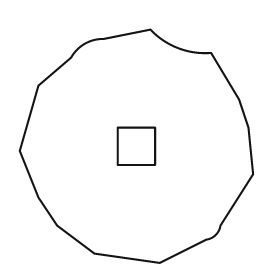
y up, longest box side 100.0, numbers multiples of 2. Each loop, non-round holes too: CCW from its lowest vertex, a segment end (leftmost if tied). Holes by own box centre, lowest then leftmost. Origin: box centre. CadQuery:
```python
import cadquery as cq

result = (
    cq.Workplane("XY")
    .moveTo(10.0, -50.0)
    .lineTo(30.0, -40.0)
    .threePointArc((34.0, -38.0), (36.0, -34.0))
    .lineTo(50.0, -12.0)
    .lineTo(48.0, 8.0)
    .lineTo(44.0, 20.0)
    .lineTo(32.0, 40.0)
    .threePointArc((18.0, 42.0), (6.0, 50.0))
    .lineTo(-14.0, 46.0)
    .threePointArc((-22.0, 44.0), (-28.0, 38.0))
    .lineTo(-42.0, 26.0)
    .lineTo(-50.0, -2.0)
    .lineTo(-42.0, -22.0)
    .lineTo(-34.0, -34.0)
    .lineTo(-18.0, -46.0)
    .close()
    .moveTo(-8.0, -8.0)
    .lineTo(8.0, -8.0)
    .lineTo(8.0, 8.0)
    .lineTo(-8.0, 8.0)
    .close()
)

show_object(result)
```